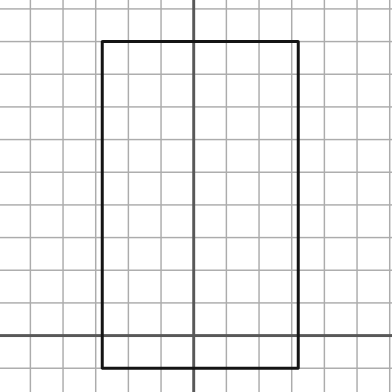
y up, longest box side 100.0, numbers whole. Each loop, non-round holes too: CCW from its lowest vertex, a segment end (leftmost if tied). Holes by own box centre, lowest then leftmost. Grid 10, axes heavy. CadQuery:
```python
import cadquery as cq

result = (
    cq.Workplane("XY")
    .moveTo(-28.0, -10.0)
    .lineTo(32.0, -10.0)
    .lineTo(32.0, 90.0)
    .lineTo(-28.0, 90.0)
    .close()
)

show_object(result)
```